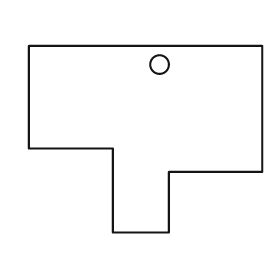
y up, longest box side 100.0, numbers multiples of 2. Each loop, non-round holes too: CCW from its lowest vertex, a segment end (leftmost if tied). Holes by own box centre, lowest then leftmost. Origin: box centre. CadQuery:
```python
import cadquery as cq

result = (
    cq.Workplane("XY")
    .moveTo(-14.0, -40.0)
    .lineTo(10.0, -40.0)
    .lineTo(10.0, -14.0)
    .lineTo(50.0, -14.0)
    .lineTo(50.0, 40.0)
    .lineTo(-50.0, 40.0)
    .lineTo(-50.0, -4.0)
    .lineTo(-14.0, -4.0)
    .close()
    .moveTo(6.0, 32.0)
    .circle(4.0)
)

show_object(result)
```